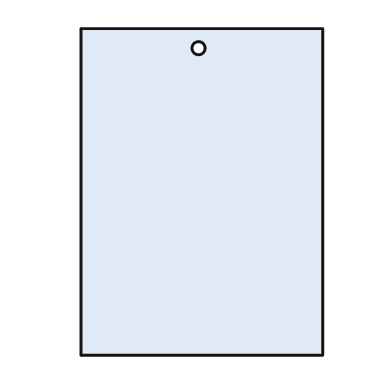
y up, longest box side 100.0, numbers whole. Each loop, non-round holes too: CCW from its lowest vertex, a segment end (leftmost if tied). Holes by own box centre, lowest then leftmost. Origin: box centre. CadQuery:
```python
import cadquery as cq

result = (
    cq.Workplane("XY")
    .moveTo(-37.0, -50.0)
    .lineTo(37.0, -50.0)
    .lineTo(37.0, 50.0)
    .lineTo(-37.0, 50.0)
    .close()
    .moveTo(-1.0, 44.0)
    .circle(2.0)
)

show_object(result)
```